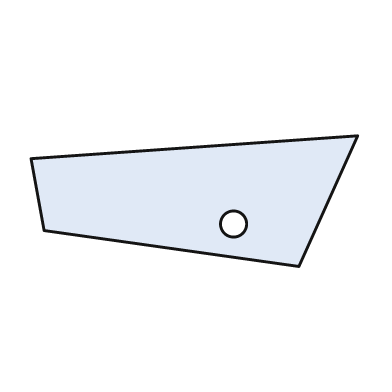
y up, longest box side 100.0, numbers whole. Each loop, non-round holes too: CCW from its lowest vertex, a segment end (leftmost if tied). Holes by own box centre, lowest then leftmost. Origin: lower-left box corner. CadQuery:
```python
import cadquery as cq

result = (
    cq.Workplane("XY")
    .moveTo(82.0, 0.0)
    .lineTo(100.0, 40.0)
    .lineTo(0.0, 33.0)
    .lineTo(4.0, 11.0)
    .close()
    .moveTo(62.0, 13.0)
    .circle(4.0)
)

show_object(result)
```